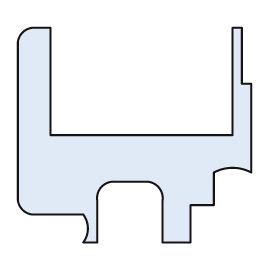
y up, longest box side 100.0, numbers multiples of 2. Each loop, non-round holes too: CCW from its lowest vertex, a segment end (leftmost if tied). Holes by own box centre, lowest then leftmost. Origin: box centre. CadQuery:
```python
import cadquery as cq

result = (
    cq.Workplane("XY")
    .moveTo(-22.0, -46.0)
    .lineTo(-16.0, -46.0)
    .lineTo(-16.0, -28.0)
    .threePointArc((-14.0, -22.0), (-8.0, -20.0))
    .lineTo(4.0, -20.0)
    .threePointArc((10.0, -22.0), (12.0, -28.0))
    .lineTo(12.0, -46.0)
    .lineTo(24.0, -46.0)
    .lineTo(24.0, -30.0)
    .lineTo(34.0, -30.0)
    .lineTo(34.0, -16.0)
    .threePointArc((42.0, -14.0), (50.0, -16.0))
    .lineTo(50.0, 22.0)
    .lineTo(46.0, 22.0)
    .lineTo(46.0, 46.0)
    .lineTo(42.0, 46.0)
    .lineTo(42.0, 0.0)
    .lineTo(-36.0, 0.0)
    .lineTo(-36.0, 46.0)
    .lineTo(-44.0, 46.0)
    .threePointArc((-48.0, 44.0), (-50.0, 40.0))
    .lineTo(-50.0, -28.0)
    .threePointArc((-48.0, -32.0), (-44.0, -34.0))
    .lineTo(-22.0, -34.0)
    .threePointArc((-20.0, -40.0), (-22.0, -46.0))
    .close()
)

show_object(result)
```